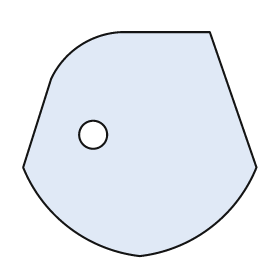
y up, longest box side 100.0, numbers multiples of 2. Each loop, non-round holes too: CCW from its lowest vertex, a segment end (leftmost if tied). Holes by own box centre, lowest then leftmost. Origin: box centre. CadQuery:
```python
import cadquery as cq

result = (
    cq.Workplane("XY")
    .moveTo(0.0, -48.0)
    .threePointArc((30.0, -36.0), (50.0, -10.0))
    .lineTo(30.0, 48.0)
    .lineTo(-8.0, 48.0)
    .threePointArc((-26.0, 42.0), (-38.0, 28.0))
    .lineTo(-50.0, -10.0)
    .threePointArc((-30.0, -36.0), (0.0, -48.0))
    .close()
    .moveTo(-20.0, 4.0)
    .circle(6.0)
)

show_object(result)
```